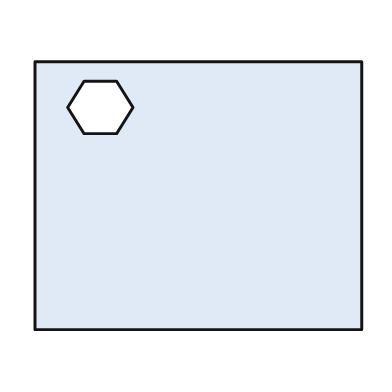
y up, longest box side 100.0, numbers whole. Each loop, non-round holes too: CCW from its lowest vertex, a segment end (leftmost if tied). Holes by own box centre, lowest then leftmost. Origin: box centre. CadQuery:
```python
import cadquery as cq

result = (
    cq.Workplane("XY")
    .moveTo(-50.0, -41.0)
    .lineTo(50.0, -41.0)
    .lineTo(50.0, 41.0)
    .lineTo(-50.0, 41.0)
    .close()
    .moveTo(-35.0, 19.0)
    .lineTo(-25.0, 19.0)
    .lineTo(-20.0, 27.0)
    .lineTo(-25.0, 35.0)
    .lineTo(-35.0, 35.0)
    .lineTo(-40.0, 27.0)
    .close()
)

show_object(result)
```